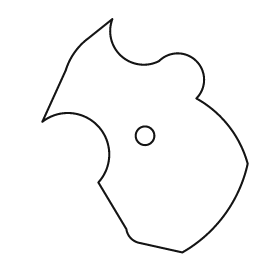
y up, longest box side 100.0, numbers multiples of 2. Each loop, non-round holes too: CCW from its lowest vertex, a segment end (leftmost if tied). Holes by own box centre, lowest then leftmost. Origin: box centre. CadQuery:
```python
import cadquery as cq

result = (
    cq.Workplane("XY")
    .moveTo(16.0, -50.0)
    .threePointArc((34.0, -34.0), (44.0, -12.0))
    .threePointArc((36.0, 4.0), (22.0, 16.0))
    .threePointArc((22.0, 32.0), (6.0, 32.0))
    .threePointArc((-10.0, 34.0), (-14.0, 50.0))
    .lineTo(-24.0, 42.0)
    .threePointArc((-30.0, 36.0), (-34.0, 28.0))
    .lineTo(-44.0, 6.0)
    .threePointArc((-20.0, 4.0), (-20.0, -20.0))
    .lineTo(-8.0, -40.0)
    .threePointArc((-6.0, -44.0), (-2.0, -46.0))
    .close()
    .moveTo(0.0, 0.0)
    .circle(4.0)
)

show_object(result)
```